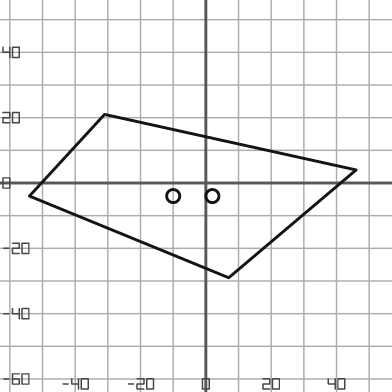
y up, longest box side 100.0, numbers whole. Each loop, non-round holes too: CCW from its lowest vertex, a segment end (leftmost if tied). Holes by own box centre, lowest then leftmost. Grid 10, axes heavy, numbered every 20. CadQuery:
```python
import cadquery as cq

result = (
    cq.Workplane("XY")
    .moveTo(7.0, -29.0)
    .lineTo(46.0, 4.0)
    .lineTo(-31.0, 21.0)
    .lineTo(-54.0, -4.0)
    .close()
    .moveTo(-10.0, -4.0)
    .circle(2.0)
    .moveTo(2.0, -4.0)
    .circle(2.0)
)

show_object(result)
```